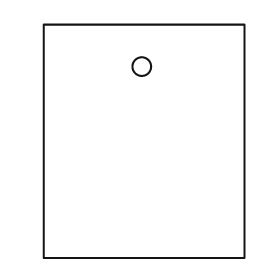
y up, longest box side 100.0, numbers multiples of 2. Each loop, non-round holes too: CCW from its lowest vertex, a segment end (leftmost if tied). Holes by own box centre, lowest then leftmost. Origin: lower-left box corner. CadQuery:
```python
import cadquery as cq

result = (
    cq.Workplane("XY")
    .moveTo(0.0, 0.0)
    .lineTo(86.0, 0.0)
    .lineTo(86.0, 100.0)
    .lineTo(0.0, 100.0)
    .close()
    .moveTo(42.0, 82.0)
    .circle(4.0)
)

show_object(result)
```